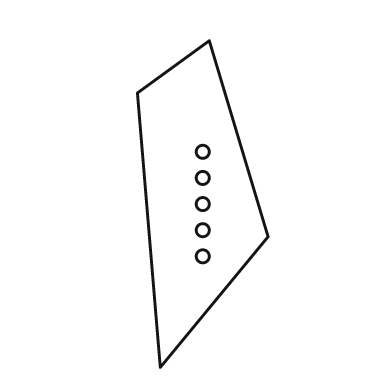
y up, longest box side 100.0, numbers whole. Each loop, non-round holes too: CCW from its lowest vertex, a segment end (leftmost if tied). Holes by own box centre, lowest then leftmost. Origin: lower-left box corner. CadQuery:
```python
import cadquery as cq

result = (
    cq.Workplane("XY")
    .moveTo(7.0, 0.0)
    .lineTo(40.0, 40.0)
    .lineTo(22.0, 100.0)
    .lineTo(0.0, 84.0)
    .close()
    .moveTo(20.0, 34.0)
    .circle(2.0)
    .moveTo(20.0, 42.0)
    .circle(2.0)
    .moveTo(20.0, 50.0)
    .circle(2.0)
    .moveTo(20.0, 58.0)
    .circle(2.0)
    .moveTo(20.0, 66.0)
    .circle(2.0)
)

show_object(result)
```